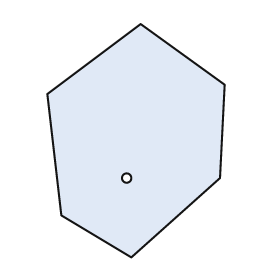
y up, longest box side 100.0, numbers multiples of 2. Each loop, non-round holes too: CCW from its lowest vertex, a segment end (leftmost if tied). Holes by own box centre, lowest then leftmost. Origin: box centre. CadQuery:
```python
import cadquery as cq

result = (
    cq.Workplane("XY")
    .moveTo(-2.0, -50.0)
    .lineTo(36.0, -16.0)
    .lineTo(38.0, 24.0)
    .lineTo(2.0, 50.0)
    .lineTo(-38.0, 20.0)
    .lineTo(-32.0, -32.0)
    .close()
    .moveTo(-4.0, -16.0)
    .circle(2.0)
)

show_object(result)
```